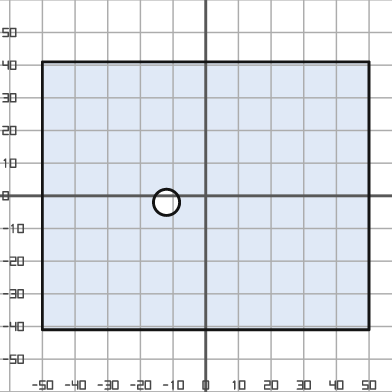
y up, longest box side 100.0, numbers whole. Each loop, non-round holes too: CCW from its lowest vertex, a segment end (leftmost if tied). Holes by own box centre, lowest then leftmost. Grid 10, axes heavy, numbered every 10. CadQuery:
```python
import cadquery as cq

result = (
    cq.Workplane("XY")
    .moveTo(-50.0, -41.0)
    .lineTo(50.0, -41.0)
    .lineTo(50.0, 41.0)
    .lineTo(-50.0, 41.0)
    .close()
    .moveTo(-12.0, -2.0)
    .circle(4.0)
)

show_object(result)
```